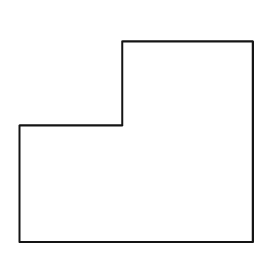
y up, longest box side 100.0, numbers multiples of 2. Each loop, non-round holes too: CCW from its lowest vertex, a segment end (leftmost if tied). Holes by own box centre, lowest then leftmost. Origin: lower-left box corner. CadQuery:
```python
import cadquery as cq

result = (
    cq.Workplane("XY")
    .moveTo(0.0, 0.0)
    .lineTo(100.0, 0.0)
    .lineTo(100.0, 86.0)
    .lineTo(44.0, 86.0)
    .lineTo(44.0, 50.0)
    .lineTo(0.0, 50.0)
    .close()
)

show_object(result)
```